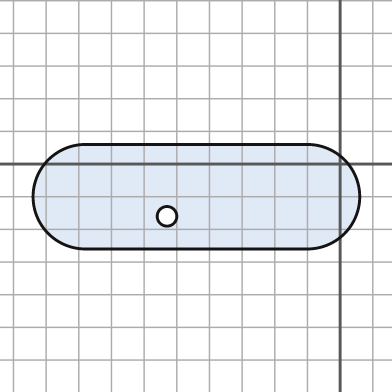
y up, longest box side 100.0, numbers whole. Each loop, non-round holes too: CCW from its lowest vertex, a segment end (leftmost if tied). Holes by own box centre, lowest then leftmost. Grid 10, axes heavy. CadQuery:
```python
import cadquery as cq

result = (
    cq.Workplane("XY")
    .moveTo(-78.0, -26.0)
    .lineTo(-10.0, -26.0)
    .threePointArc((6.0, -10.0), (-10.0, 6.0))
    .lineTo(-78.0, 6.0)
    .threePointArc((-94.0, -10.0), (-78.0, -26.0))
    .close()
    .moveTo(-53.0, -16.0)
    .circle(3.0)
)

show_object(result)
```